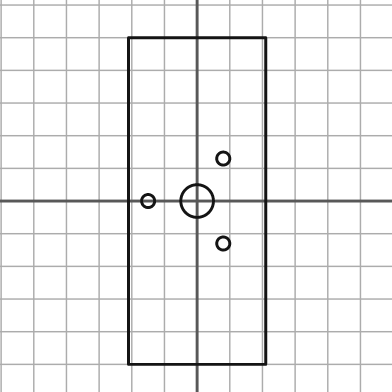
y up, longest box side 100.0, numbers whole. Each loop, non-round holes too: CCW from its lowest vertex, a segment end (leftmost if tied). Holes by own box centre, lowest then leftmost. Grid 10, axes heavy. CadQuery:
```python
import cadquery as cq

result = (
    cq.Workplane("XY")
    .moveTo(-21.0, -50.0)
    .lineTo(21.0, -50.0)
    .lineTo(21.0, 50.0)
    .lineTo(-21.0, 50.0)
    .close()
    .moveTo(8.0, -13.0)
    .circle(2.0)
    .moveTo(-15.0, 0.0)
    .circle(2.0)
    .moveTo(0.0, 0.0)
    .circle(5.0)
    .moveTo(8.0, 13.0)
    .circle(2.0)
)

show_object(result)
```